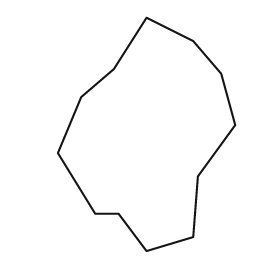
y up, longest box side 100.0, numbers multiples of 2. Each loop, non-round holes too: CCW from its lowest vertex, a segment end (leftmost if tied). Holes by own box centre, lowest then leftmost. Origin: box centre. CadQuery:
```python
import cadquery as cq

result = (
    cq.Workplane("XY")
    .moveTo(0.0, -50.0)
    .lineTo(20.0, -44.0)
    .lineTo(22.0, -18.0)
    .lineTo(38.0, 4.0)
    .lineTo(32.0, 26.0)
    .lineTo(20.0, 40.0)
    .lineTo(0.0, 50.0)
    .lineTo(-14.0, 28.0)
    .lineTo(-28.0, 16.0)
    .lineTo(-38.0, -8.0)
    .lineTo(-22.0, -34.0)
    .lineTo(-12.0, -34.0)
    .close()
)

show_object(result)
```